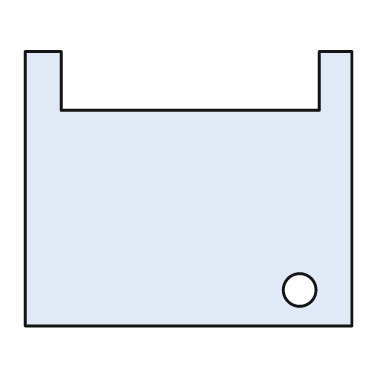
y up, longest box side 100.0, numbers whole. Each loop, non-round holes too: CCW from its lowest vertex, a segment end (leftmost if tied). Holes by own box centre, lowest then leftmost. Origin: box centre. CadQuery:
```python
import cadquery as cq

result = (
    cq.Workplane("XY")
    .moveTo(-50.0, -42.0)
    .lineTo(50.0, -42.0)
    .lineTo(50.0, 42.0)
    .lineTo(40.0, 42.0)
    .lineTo(40.0, 24.0)
    .lineTo(-39.0, 24.0)
    .lineTo(-39.0, 42.0)
    .lineTo(-50.0, 42.0)
    .close()
    .moveTo(34.0, -31.0)
    .circle(5.0)
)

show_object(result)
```